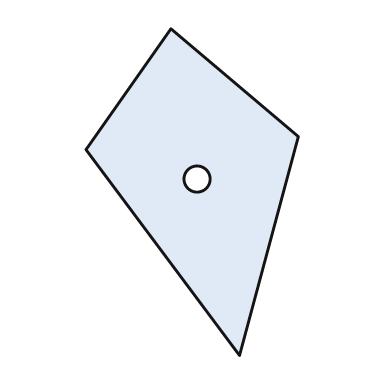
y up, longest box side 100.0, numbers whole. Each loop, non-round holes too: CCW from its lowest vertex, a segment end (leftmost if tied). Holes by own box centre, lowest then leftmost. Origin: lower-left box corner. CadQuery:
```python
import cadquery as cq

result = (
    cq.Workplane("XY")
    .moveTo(47.0, 0.0)
    .lineTo(65.0, 67.0)
    .lineTo(26.0, 100.0)
    .lineTo(0.0, 63.0)
    .close()
    .moveTo(34.0, 54.0)
    .circle(4.0)
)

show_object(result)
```